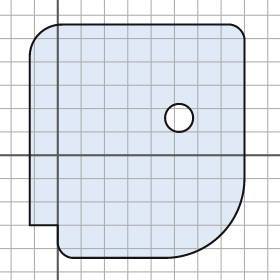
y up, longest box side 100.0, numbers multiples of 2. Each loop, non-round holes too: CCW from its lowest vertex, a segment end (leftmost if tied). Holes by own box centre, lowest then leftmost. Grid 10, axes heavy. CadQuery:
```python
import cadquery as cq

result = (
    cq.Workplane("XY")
    .moveTo(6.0, -44.0)
    .lineTo(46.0, -44.0)
    .threePointArc((70.0, -34.0), (80.0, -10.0))
    .lineTo(80.0, 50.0)
    .threePointArc((78.0, 54.0), (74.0, 56.0))
    .lineTo(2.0, 56.0)
    .threePointArc((-8.0, 52.0), (-12.0, 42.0))
    .lineTo(-12.0, -30.0)
    .lineTo(0.0, -30.0)
    .lineTo(0.0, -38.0)
    .threePointArc((2.0, -42.0), (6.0, -44.0))
    .close()
    .moveTo(52.0, 16.0)
    .circle(6.0)
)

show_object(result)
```